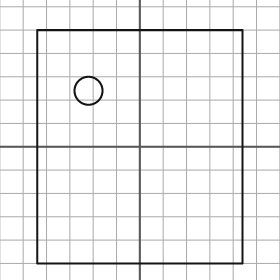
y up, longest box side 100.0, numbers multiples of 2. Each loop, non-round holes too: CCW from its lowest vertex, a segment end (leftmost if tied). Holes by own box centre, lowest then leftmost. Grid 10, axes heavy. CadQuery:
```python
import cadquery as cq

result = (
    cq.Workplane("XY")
    .moveTo(-44.0, -50.0)
    .lineTo(44.0, -50.0)
    .lineTo(44.0, 50.0)
    .lineTo(-44.0, 50.0)
    .close()
    .moveTo(-22.0, 24.0)
    .circle(6.0)
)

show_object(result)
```